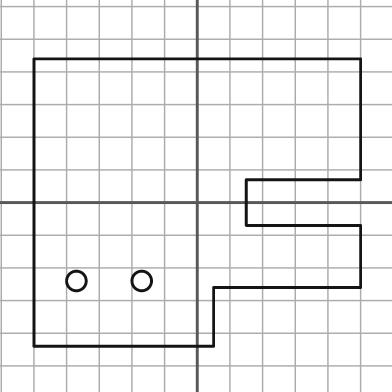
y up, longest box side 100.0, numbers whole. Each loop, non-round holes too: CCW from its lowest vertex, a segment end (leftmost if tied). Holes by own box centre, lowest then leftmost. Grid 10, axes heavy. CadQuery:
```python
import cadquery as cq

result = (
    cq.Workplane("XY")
    .moveTo(-50.0, -44.0)
    .lineTo(5.0, -44.0)
    .lineTo(5.0, -26.0)
    .lineTo(50.0, -26.0)
    .lineTo(50.0, -7.0)
    .lineTo(15.0, -7.0)
    .lineTo(15.0, 7.0)
    .lineTo(50.0, 7.0)
    .lineTo(50.0, 44.0)
    .lineTo(-50.0, 44.0)
    .close()
    .moveTo(-37.0, -24.0)
    .circle(3.0)
    .moveTo(-17.0, -24.0)
    .circle(3.0)
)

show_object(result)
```